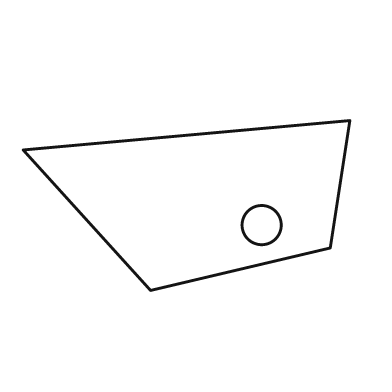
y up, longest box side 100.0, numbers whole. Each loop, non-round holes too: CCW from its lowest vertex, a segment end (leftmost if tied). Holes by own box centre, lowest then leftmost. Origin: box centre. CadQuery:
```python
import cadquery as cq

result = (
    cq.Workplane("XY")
    .moveTo(-11.0, -26.0)
    .lineTo(44.0, -13.0)
    .lineTo(50.0, 26.0)
    .lineTo(-50.0, 17.0)
    .close()
    .moveTo(23.0, -6.0)
    .circle(6.0)
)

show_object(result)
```